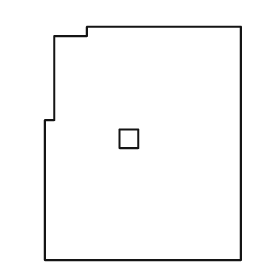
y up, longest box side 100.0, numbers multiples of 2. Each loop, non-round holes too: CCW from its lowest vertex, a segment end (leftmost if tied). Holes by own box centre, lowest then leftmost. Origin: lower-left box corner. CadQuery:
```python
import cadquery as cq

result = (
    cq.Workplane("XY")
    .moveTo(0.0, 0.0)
    .lineTo(84.0, 0.0)
    .lineTo(84.0, 100.0)
    .lineTo(18.0, 100.0)
    .lineTo(18.0, 96.0)
    .lineTo(4.0, 96.0)
    .lineTo(4.0, 60.0)
    .lineTo(0.0, 60.0)
    .close()
    .moveTo(32.0, 48.0)
    .lineTo(40.0, 48.0)
    .lineTo(40.0, 56.0)
    .lineTo(32.0, 56.0)
    .close()
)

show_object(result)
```